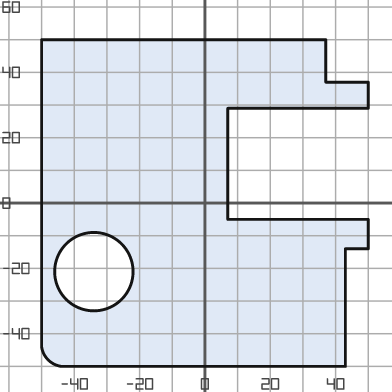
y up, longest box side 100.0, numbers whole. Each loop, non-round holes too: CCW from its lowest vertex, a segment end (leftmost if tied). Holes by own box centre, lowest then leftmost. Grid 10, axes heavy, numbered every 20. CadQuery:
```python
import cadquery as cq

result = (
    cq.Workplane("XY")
    .moveTo(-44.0, -50.0)
    .lineTo(43.0, -50.0)
    .lineTo(43.0, -14.0)
    .lineTo(50.0, -14.0)
    .lineTo(50.0, -5.0)
    .lineTo(7.0, -5.0)
    .lineTo(7.0, 29.0)
    .lineTo(50.0, 29.0)
    .lineTo(50.0, 37.0)
    .lineTo(37.0, 37.0)
    .lineTo(37.0, 50.0)
    .lineTo(-50.0, 50.0)
    .lineTo(-50.0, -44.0)
    .threePointArc((-48.0, -48.0), (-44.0, -50.0))
    .close()
    .moveTo(-34.0, -21.0)
    .circle(12.0)
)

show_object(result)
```